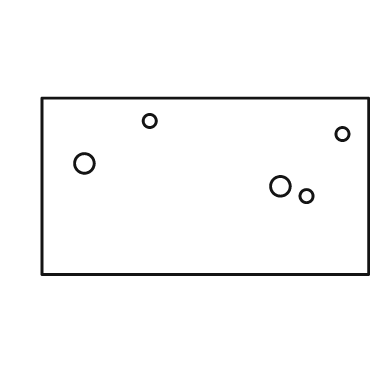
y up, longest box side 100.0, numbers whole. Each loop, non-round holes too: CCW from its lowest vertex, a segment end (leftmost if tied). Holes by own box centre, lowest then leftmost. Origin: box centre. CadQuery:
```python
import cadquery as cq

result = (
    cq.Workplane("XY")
    .moveTo(-50.0, -27.0)
    .lineTo(50.0, -27.0)
    .lineTo(50.0, 27.0)
    .lineTo(-50.0, 27.0)
    .close()
    .moveTo(31.0, -3.0)
    .circle(2.0)
    .moveTo(23.0, 0.0)
    .circle(3.0)
    .moveTo(-37.0, 7.0)
    .circle(3.0)
    .moveTo(42.0, 16.0)
    .circle(2.0)
    .moveTo(-17.0, 20.0)
    .circle(2.0)
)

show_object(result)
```